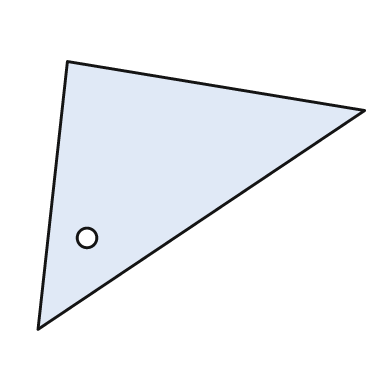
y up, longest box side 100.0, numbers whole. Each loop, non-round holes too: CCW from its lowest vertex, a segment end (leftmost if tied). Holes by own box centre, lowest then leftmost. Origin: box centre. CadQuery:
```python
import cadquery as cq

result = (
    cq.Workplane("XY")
    .moveTo(-50.0, -41.0)
    .lineTo(50.0, 26.0)
    .lineTo(-41.0, 41.0)
    .close()
    .moveTo(-35.0, -13.0)
    .circle(3.0)
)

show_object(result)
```